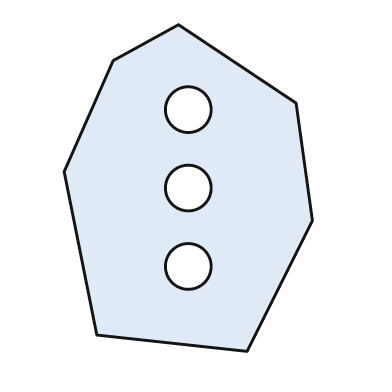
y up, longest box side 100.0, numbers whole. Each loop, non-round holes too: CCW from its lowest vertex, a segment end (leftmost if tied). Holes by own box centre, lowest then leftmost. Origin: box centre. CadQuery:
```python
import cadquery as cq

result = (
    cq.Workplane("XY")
    .moveTo(18.0, -50.0)
    .lineTo(38.0, -10.0)
    .lineTo(33.0, 26.0)
    .lineTo(-3.0, 50.0)
    .lineTo(-23.0, 39.0)
    .lineTo(-38.0, 5.0)
    .lineTo(-28.0, -45.0)
    .close()
    .moveTo(0.0, -24.0)
    .circle(7.0)
    .moveTo(0.0, 0.0)
    .circle(7.0)
    .moveTo(0.0, 24.0)
    .circle(7.0)
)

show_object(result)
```